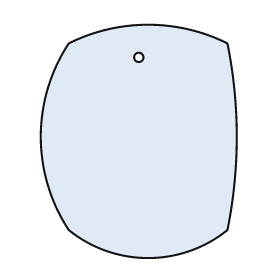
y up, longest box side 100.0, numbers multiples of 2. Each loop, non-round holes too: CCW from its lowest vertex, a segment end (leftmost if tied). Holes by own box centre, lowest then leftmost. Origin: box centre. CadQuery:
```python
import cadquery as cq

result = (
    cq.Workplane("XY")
    .moveTo(-30.0, -38.0)
    .threePointArc((4.0, -50.0), (38.0, -38.0))
    .threePointArc((42.0, 2.0), (38.0, 42.0))
    .threePointArc((4.0, 50.0), (-30.0, 42.0))
    .threePointArc((-42.0, 2.0), (-30.0, -38.0))
    .close()
    .moveTo(0.0, 36.0)
    .circle(2.0)
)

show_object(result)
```